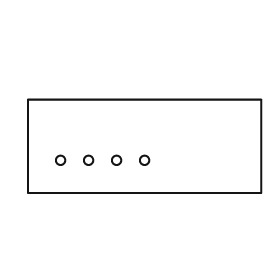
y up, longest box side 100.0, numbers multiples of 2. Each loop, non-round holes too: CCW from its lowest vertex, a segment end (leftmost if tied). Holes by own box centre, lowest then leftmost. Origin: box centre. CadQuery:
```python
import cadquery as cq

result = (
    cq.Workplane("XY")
    .moveTo(-50.0, -20.0)
    .lineTo(50.0, -20.0)
    .lineTo(50.0, 20.0)
    .lineTo(-50.0, 20.0)
    .close()
    .moveTo(-36.0, -6.0)
    .circle(2.0)
    .moveTo(-24.0, -6.0)
    .circle(2.0)
    .moveTo(-12.0, -6.0)
    .circle(2.0)
    .moveTo(0.0, -6.0)
    .circle(2.0)
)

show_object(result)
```